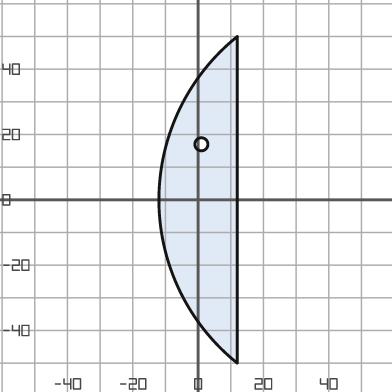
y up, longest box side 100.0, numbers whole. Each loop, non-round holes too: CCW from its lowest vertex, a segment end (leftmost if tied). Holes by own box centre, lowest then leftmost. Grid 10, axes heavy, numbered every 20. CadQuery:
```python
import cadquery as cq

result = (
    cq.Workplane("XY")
    .moveTo(12.0, -50.0)
    .lineTo(12.0, 50.0)
    .threePointArc((-12.0, 0.0), (12.0, -50.0))
    .close()
    .moveTo(1.0, 17.0)
    .circle(2.0)
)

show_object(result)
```